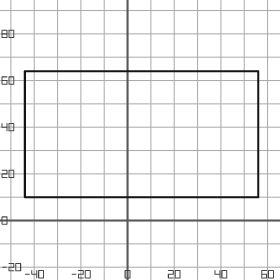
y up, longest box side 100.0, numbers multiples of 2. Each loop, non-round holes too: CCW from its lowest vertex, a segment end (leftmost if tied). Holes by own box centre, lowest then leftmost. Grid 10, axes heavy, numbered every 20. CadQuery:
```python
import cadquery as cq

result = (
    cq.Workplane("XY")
    .moveTo(-44.0, 10.0)
    .lineTo(56.0, 10.0)
    .lineTo(56.0, 64.0)
    .lineTo(-44.0, 64.0)
    .close()
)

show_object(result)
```